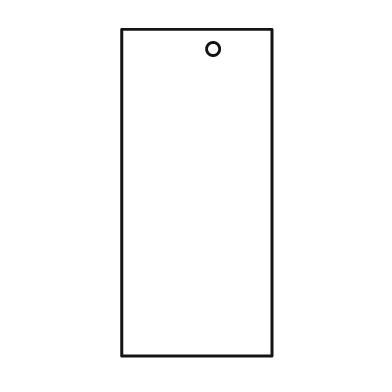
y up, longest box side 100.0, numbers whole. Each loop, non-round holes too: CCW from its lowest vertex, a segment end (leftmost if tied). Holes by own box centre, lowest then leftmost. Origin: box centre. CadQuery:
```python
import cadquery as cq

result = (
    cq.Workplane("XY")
    .moveTo(-23.0, -50.0)
    .lineTo(23.0, -50.0)
    .lineTo(23.0, 50.0)
    .lineTo(-23.0, 50.0)
    .close()
    .moveTo(5.0, 44.0)
    .circle(2.0)
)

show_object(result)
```